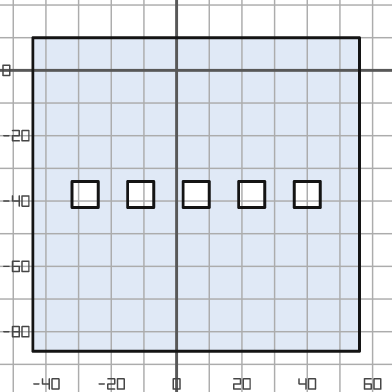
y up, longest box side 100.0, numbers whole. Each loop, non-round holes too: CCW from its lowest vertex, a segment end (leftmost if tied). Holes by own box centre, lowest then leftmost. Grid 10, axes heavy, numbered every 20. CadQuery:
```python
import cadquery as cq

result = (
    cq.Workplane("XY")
    .moveTo(-44.0, -86.0)
    .lineTo(56.0, -86.0)
    .lineTo(56.0, 10.0)
    .lineTo(-44.0, 10.0)
    .close()
    .moveTo(-32.0, -42.0)
    .lineTo(-24.0, -42.0)
    .lineTo(-24.0, -34.0)
    .lineTo(-32.0, -34.0)
    .close()
    .moveTo(-15.0, -42.0)
    .lineTo(-7.0, -42.0)
    .lineTo(-7.0, -34.0)
    .lineTo(-15.0, -34.0)
    .close()
    .moveTo(2.0, -42.0)
    .lineTo(10.0, -42.0)
    .lineTo(10.0, -34.0)
    .lineTo(2.0, -34.0)
    .close()
    .moveTo(19.0, -42.0)
    .lineTo(27.0, -42.0)
    .lineTo(27.0, -34.0)
    .lineTo(19.0, -34.0)
    .close()
    .moveTo(36.0, -42.0)
    .lineTo(44.0, -42.0)
    .lineTo(44.0, -34.0)
    .lineTo(36.0, -34.0)
    .close()
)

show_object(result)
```